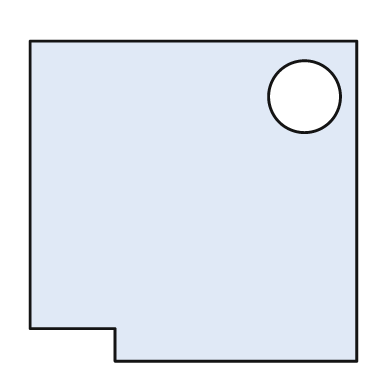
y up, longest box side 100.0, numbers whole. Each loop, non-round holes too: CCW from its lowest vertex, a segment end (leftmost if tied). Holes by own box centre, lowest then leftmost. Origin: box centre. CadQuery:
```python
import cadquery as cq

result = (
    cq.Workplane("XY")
    .moveTo(-24.0, -49.0)
    .lineTo(50.0, -49.0)
    .lineTo(50.0, 49.0)
    .lineTo(-50.0, 49.0)
    .lineTo(-50.0, -39.0)
    .lineTo(-24.0, -39.0)
    .close()
    .moveTo(34.0, 32.0)
    .circle(11.0)
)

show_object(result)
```